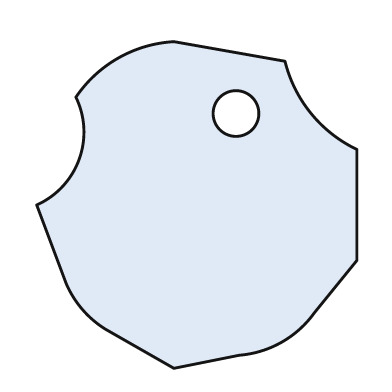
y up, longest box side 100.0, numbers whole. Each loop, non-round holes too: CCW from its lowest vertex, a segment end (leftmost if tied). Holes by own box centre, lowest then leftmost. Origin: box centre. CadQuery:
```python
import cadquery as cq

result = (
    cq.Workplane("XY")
    .moveTo(-7.0, -50.0)
    .lineTo(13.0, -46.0)
    .threePointArc((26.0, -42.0), (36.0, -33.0))
    .lineTo(49.0, -17.0)
    .lineTo(49.0, 17.0)
    .threePointArc((35.0, 28.0), (27.0, 44.0))
    .lineTo(-7.0, 50.0)
    .threePointArc((-24.0, 45.0), (-37.0, 33.0))
    .threePointArc((-36.0, 14.0), (-49.0, 0.0))
    .lineTo(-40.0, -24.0)
    .threePointArc((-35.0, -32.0), (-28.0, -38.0))
    .close()
    .moveTo(12.0, 28.0)
    .circle(7.0)
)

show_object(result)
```